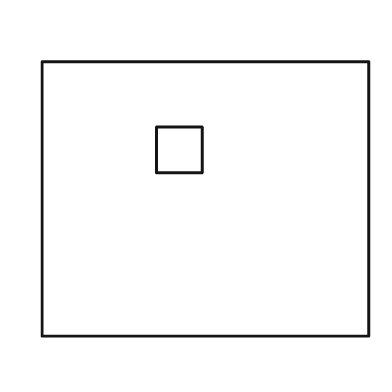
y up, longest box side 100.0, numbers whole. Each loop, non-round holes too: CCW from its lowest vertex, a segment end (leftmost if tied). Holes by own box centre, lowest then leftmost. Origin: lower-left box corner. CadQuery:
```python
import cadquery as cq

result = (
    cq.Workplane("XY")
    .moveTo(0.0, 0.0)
    .lineTo(100.0, 0.0)
    .lineTo(100.0, 84.0)
    .lineTo(0.0, 84.0)
    .close()
    .moveTo(35.0, 50.0)
    .lineTo(49.0, 50.0)
    .lineTo(49.0, 64.0)
    .lineTo(35.0, 64.0)
    .close()
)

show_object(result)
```